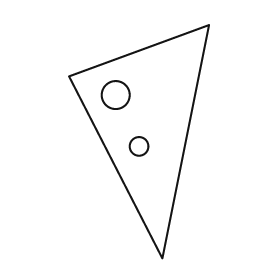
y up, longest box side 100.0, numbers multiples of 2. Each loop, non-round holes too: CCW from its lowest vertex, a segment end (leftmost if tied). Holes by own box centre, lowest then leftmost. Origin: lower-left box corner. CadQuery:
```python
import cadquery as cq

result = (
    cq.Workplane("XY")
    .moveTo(40.0, 0.0)
    .lineTo(60.0, 100.0)
    .lineTo(0.0, 78.0)
    .close()
    .moveTo(30.0, 48.0)
    .circle(4.0)
    .moveTo(20.0, 70.0)
    .circle(6.0)
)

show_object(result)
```